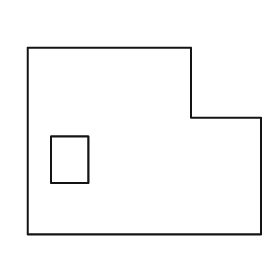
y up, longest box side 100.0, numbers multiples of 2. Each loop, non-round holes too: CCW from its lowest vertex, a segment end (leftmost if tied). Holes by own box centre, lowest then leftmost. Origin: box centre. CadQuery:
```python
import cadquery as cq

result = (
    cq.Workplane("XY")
    .moveTo(-50.0, -40.0)
    .lineTo(50.0, -40.0)
    .lineTo(50.0, 10.0)
    .lineTo(20.0, 10.0)
    .lineTo(20.0, 40.0)
    .lineTo(-50.0, 40.0)
    .close()
    .moveTo(-40.0, -18.0)
    .lineTo(-24.0, -18.0)
    .lineTo(-24.0, 2.0)
    .lineTo(-40.0, 2.0)
    .close()
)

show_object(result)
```